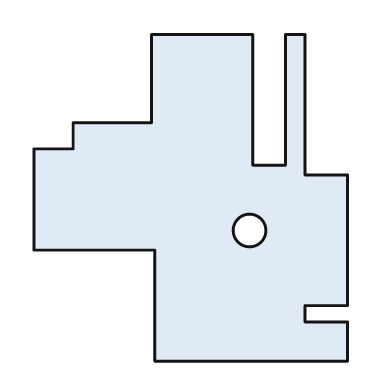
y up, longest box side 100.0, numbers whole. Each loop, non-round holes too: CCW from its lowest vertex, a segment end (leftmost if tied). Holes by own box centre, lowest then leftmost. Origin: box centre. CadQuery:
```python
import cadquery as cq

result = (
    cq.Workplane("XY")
    .moveTo(-11.0, -50.0)
    .lineTo(48.0, -50.0)
    .lineTo(48.0, -38.0)
    .lineTo(35.0, -38.0)
    .lineTo(35.0, -33.0)
    .lineTo(48.0, -33.0)
    .lineTo(48.0, 7.0)
    .lineTo(35.0, 7.0)
    .lineTo(35.0, 50.0)
    .lineTo(29.0, 50.0)
    .lineTo(29.0, 10.0)
    .lineTo(19.0, 10.0)
    .lineTo(19.0, 50.0)
    .lineTo(-12.0, 50.0)
    .lineTo(-12.0, 23.0)
    .lineTo(-36.0, 23.0)
    .lineTo(-36.0, 15.0)
    .lineTo(-48.0, 15.0)
    .lineTo(-48.0, -16.0)
    .lineTo(-11.0, -16.0)
    .close()
    .moveTo(18.0, -10.0)
    .circle(5.0)
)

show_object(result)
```